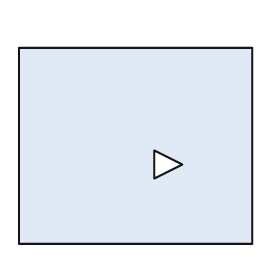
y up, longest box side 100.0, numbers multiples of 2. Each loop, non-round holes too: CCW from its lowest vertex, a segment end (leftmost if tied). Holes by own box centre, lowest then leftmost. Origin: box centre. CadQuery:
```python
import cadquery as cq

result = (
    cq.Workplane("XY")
    .moveTo(-50.0, -42.0)
    .lineTo(50.0, -42.0)
    .lineTo(50.0, 42.0)
    .lineTo(-50.0, 42.0)
    .close()
    .moveTo(8.0, -14.0)
    .lineTo(20.0, -8.0)
    .lineTo(8.0, -2.0)
    .close()
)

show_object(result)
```